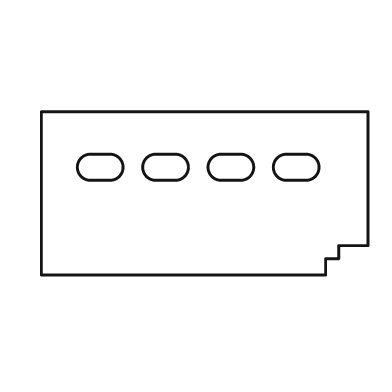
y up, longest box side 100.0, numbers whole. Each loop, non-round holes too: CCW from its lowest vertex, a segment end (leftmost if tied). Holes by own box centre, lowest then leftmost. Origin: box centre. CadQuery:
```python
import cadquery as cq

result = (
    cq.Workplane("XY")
    .moveTo(-50.0, -25.0)
    .lineTo(37.0, -25.0)
    .lineTo(37.0, -20.0)
    .lineTo(41.0, -20.0)
    .lineTo(41.0, -16.0)
    .lineTo(50.0, -16.0)
    .lineTo(50.0, 25.0)
    .lineTo(-50.0, 25.0)
    .close()
    .moveTo(-35.0, 4.0)
    .lineTo(-29.0, 4.0)
    .threePointArc((-25.0, 8.0), (-29.0, 12.0))
    .lineTo(-35.0, 12.0)
    .threePointArc((-39.0, 8.0), (-35.0, 4.0))
    .close()
    .moveTo(-15.0, 4.0)
    .lineTo(-9.0, 4.0)
    .threePointArc((-5.0, 8.0), (-9.0, 12.0))
    .lineTo(-15.0, 12.0)
    .threePointArc((-19.0, 8.0), (-15.0, 4.0))
    .close()
    .moveTo(5.0, 4.0)
    .lineTo(11.0, 4.0)
    .threePointArc((15.0, 8.0), (11.0, 12.0))
    .lineTo(5.0, 12.0)
    .threePointArc((1.0, 8.0), (5.0, 4.0))
    .close()
    .moveTo(25.0, 4.0)
    .lineTo(31.0, 4.0)
    .threePointArc((35.0, 8.0), (31.0, 12.0))
    .lineTo(25.0, 12.0)
    .threePointArc((21.0, 8.0), (25.0, 4.0))
    .close()
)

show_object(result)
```